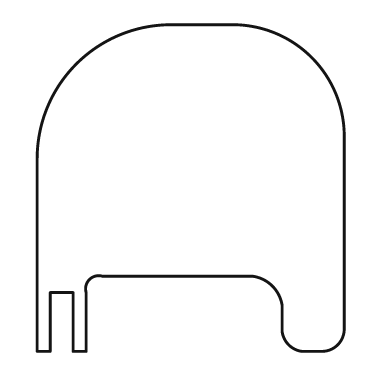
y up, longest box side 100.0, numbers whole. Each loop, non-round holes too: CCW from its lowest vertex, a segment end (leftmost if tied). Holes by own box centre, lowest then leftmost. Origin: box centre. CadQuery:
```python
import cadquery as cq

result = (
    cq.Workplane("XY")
    .moveTo(-47.0, -50.0)
    .lineTo(-43.0, -50.0)
    .lineTo(-43.0, -32.0)
    .lineTo(-36.0, -32.0)
    .lineTo(-36.0, -50.0)
    .lineTo(-32.0, -50.0)
    .lineTo(-32.0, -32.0)
    .threePointArc((-31.0, -28.0), (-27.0, -27.0))
    .lineTo(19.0, -27.0)
    .threePointArc((25.0, -30.0), (28.0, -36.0))
    .lineTo(28.0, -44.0)
    .threePointArc((30.0, -48.0), (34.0, -50.0))
    .lineTo(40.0, -50.0)
    .threePointArc((45.0, -48.0), (47.0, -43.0))
    .lineTo(47.0, 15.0)
    .threePointArc((37.0, 40.0), (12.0, 50.0))
    .lineTo(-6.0, 50.0)
    .threePointArc((-35.0, 38.0), (-47.0, 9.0))
    .close()
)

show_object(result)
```